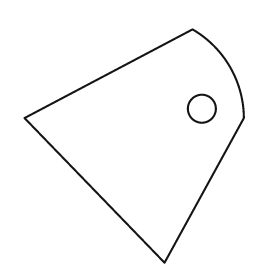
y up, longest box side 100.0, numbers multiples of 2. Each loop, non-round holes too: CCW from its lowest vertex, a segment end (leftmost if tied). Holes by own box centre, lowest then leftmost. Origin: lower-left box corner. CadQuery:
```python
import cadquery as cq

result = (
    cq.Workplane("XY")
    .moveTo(60.0, 0.0)
    .lineTo(94.0, 62.0)
    .threePointArc((88.0, 84.0), (72.0, 100.0))
    .lineTo(0.0, 62.0)
    .close()
    .moveTo(76.0, 66.0)
    .circle(6.0)
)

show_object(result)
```